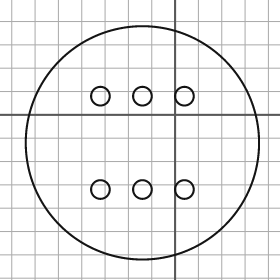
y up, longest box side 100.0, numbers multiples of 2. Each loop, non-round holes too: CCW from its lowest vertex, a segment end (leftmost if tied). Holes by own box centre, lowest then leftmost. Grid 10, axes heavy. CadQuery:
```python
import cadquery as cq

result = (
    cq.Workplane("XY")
    .moveTo(-14.0, -12.0)
    .circle(50.0)
    .moveTo(-32.0, -32.0)
    .circle(4.0)
    .moveTo(-14.0, -32.0)
    .circle(4.0)
    .moveTo(4.0, -32.0)
    .circle(4.0)
    .moveTo(-32.0, 8.0)
    .circle(4.0)
    .moveTo(-14.0, 8.0)
    .circle(4.0)
    .moveTo(4.0, 8.0)
    .circle(4.0)
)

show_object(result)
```